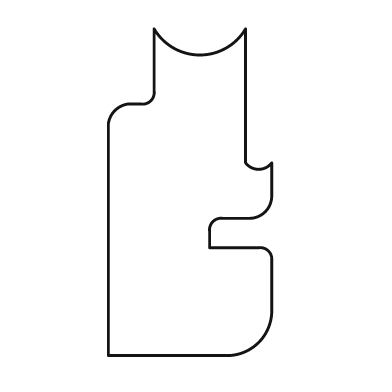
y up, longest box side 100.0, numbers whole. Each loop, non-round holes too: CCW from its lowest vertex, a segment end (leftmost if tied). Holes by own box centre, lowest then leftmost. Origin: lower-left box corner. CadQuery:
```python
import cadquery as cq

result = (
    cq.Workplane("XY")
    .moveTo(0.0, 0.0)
    .lineTo(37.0, 0.0)
    .threePointArc((46.0, 4.0), (50.0, 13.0))
    .lineTo(50.0, 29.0)
    .threePointArc((49.0, 32.0), (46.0, 33.0))
    .lineTo(31.0, 33.0)
    .lineTo(31.0, 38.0)
    .threePointArc((32.0, 41.0), (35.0, 42.0))
    .lineTo(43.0, 42.0)
    .threePointArc((48.0, 44.0), (50.0, 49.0))
    .lineTo(50.0, 59.0)
    .threePointArc((46.0, 57.0), (42.0, 59.0))
    .lineTo(42.0, 100.0)
    .threePointArc((28.0, 92.0), (14.0, 100.0))
    .lineTo(14.0, 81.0)
    .threePointArc((13.0, 78.0), (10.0, 77.0))
    .lineTo(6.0, 77.0)
    .threePointArc((2.0, 75.0), (0.0, 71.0))
    .close()
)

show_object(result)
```